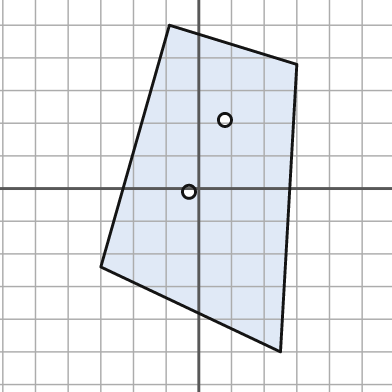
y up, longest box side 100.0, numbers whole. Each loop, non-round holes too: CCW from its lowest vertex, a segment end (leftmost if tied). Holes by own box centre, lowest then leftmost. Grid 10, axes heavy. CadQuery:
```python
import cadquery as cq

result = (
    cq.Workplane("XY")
    .moveTo(25.0, -50.0)
    .lineTo(30.0, 38.0)
    .lineTo(-9.0, 50.0)
    .lineTo(-30.0, -24.0)
    .close()
    .moveTo(-3.0, -1.0)
    .circle(2.0)
    .moveTo(8.0, 21.0)
    .circle(2.0)
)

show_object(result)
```